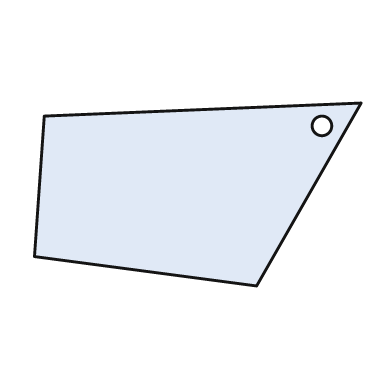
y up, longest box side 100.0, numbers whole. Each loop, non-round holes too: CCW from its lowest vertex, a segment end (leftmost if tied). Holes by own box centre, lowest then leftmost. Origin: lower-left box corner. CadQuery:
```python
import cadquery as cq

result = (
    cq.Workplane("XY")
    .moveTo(68.0, 0.0)
    .lineTo(100.0, 56.0)
    .lineTo(3.0, 52.0)
    .lineTo(0.0, 9.0)
    .close()
    .moveTo(88.0, 49.0)
    .circle(3.0)
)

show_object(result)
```